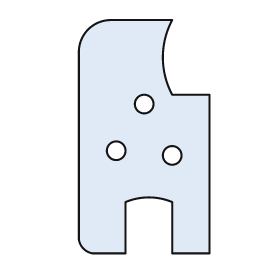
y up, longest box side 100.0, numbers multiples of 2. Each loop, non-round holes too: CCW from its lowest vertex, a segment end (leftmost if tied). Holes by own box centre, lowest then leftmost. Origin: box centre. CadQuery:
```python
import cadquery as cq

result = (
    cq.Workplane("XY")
    .moveTo(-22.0, -50.0)
    .lineTo(-8.0, -50.0)
    .lineTo(-8.0, -28.0)
    .threePointArc((2.0, -26.0), (12.0, -28.0))
    .lineTo(12.0, -50.0)
    .lineTo(28.0, -50.0)
    .lineTo(28.0, 18.0)
    .lineTo(12.0, 18.0)
    .threePointArc((8.0, 34.0), (12.0, 50.0))
    .lineTo(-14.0, 50.0)
    .threePointArc((-24.0, 46.0), (-28.0, 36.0))
    .lineTo(-28.0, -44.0)
    .threePointArc((-26.0, -48.0), (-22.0, -50.0))
    .close()
    .moveTo(12.0, -8.0)
    .circle(4.0)
    .moveTo(-12.0, -6.0)
    .circle(4.0)
    .moveTo(0.0, 14.0)
    .circle(4.0)
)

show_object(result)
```